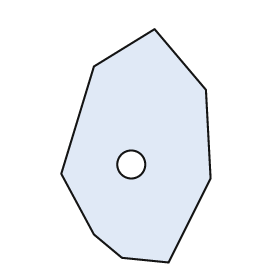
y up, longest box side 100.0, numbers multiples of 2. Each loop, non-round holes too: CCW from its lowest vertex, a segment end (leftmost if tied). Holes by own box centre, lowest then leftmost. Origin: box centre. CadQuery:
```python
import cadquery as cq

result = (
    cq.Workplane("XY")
    .moveTo(14.0, -50.0)
    .lineTo(32.0, -14.0)
    .lineTo(30.0, 24.0)
    .lineTo(8.0, 50.0)
    .lineTo(-18.0, 34.0)
    .lineTo(-32.0, -12.0)
    .lineTo(-18.0, -38.0)
    .lineTo(-6.0, -48.0)
    .close()
    .moveTo(-2.0, -8.0)
    .circle(6.0)
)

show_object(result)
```